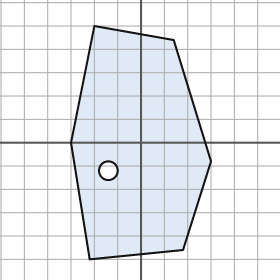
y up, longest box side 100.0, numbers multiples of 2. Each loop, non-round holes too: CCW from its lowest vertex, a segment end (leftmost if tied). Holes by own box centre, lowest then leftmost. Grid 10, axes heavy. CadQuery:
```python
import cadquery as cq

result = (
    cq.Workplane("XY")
    .moveTo(-22.0, -50.0)
    .lineTo(18.0, -46.0)
    .lineTo(30.0, -8.0)
    .lineTo(14.0, 44.0)
    .lineTo(-20.0, 50.0)
    .lineTo(-30.0, 0.0)
    .close()
    .moveTo(-14.0, -12.0)
    .circle(4.0)
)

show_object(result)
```